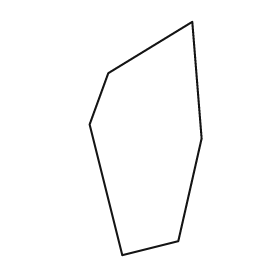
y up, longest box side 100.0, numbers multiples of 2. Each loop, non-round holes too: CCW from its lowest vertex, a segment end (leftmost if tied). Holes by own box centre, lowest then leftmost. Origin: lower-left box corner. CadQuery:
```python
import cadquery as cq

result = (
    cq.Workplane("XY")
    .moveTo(14.0, 0.0)
    .lineTo(38.0, 6.0)
    .lineTo(48.0, 50.0)
    .lineTo(44.0, 100.0)
    .lineTo(8.0, 78.0)
    .lineTo(0.0, 56.0)
    .close()
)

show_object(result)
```